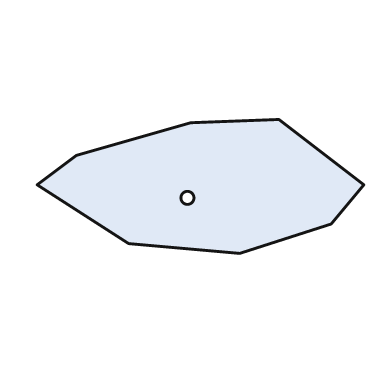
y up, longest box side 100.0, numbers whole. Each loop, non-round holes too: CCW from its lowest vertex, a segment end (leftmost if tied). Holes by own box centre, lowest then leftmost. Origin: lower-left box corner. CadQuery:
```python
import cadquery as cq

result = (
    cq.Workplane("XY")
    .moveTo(62.0, 0.0)
    .lineTo(90.0, 9.0)
    .lineTo(100.0, 21.0)
    .lineTo(74.0, 41.0)
    .lineTo(47.0, 40.0)
    .lineTo(12.0, 30.0)
    .lineTo(0.0, 21.0)
    .lineTo(28.0, 3.0)
    .close()
    .moveTo(46.0, 17.0)
    .circle(2.0)
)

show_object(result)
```